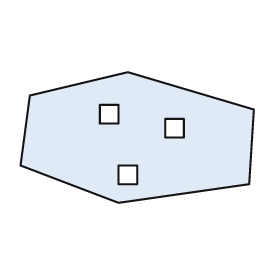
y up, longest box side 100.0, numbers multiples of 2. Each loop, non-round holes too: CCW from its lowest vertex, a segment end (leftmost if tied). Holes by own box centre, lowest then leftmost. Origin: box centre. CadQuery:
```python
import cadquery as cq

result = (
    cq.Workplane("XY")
    .moveTo(-8.0, -28.0)
    .lineTo(48.0, -20.0)
    .lineTo(50.0, 12.0)
    .lineTo(-4.0, 28.0)
    .lineTo(-46.0, 18.0)
    .lineTo(-50.0, -12.0)
    .close()
    .moveTo(-8.0, -20.0)
    .lineTo(0.0, -20.0)
    .lineTo(0.0, -12.0)
    .lineTo(-8.0, -12.0)
    .close()
    .moveTo(12.0, 0.0)
    .lineTo(20.0, 0.0)
    .lineTo(20.0, 8.0)
    .lineTo(12.0, 8.0)
    .close()
    .moveTo(-16.0, 6.0)
    .lineTo(-8.0, 6.0)
    .lineTo(-8.0, 14.0)
    .lineTo(-16.0, 14.0)
    .close()
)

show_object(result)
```